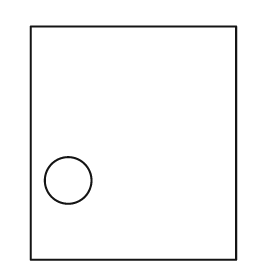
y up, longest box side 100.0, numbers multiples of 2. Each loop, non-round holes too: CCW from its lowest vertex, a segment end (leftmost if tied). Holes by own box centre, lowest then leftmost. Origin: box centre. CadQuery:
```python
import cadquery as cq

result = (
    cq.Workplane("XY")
    .moveTo(-44.0, -50.0)
    .lineTo(44.0, -50.0)
    .lineTo(44.0, 50.0)
    .lineTo(-44.0, 50.0)
    .close()
    .moveTo(-28.0, -16.0)
    .circle(10.0)
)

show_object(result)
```